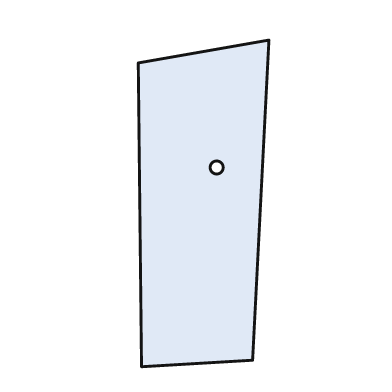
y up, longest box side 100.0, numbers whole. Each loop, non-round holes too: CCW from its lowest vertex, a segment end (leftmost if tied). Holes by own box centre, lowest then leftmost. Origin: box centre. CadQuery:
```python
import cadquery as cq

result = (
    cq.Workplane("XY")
    .moveTo(-19.0, -50.0)
    .lineTo(15.0, -48.0)
    .lineTo(20.0, 50.0)
    .lineTo(-20.0, 43.0)
    .close()
    .moveTo(4.0, 11.0)
    .circle(2.0)
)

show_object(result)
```